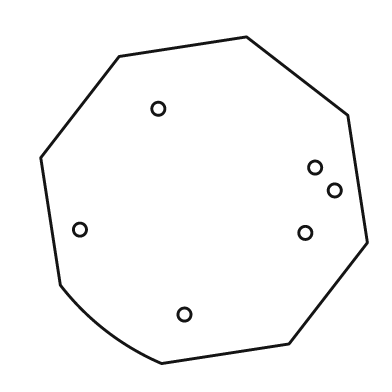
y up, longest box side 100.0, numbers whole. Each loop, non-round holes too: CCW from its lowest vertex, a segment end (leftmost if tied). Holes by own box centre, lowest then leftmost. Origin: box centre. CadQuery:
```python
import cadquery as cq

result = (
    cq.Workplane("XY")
    .moveTo(-13.0, -50.0)
    .lineTo(26.0, -44.0)
    .lineTo(50.0, -13.0)
    .lineTo(44.0, 26.0)
    .lineTo(13.0, 50.0)
    .lineTo(-26.0, 44.0)
    .lineTo(-50.0, 13.0)
    .lineTo(-44.0, -26.0)
    .threePointArc((-30.0, -40.0), (-13.0, -50.0))
    .close()
    .moveTo(-6.0, -35.0)
    .circle(2.0)
    .moveTo(31.0, -10.0)
    .circle(2.0)
    .moveTo(-38.0, -9.0)
    .circle(2.0)
    .moveTo(40.0, 3.0)
    .circle(2.0)
    .moveTo(34.0, 10.0)
    .circle(2.0)
    .moveTo(-14.0, 28.0)
    .circle(2.0)
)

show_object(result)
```